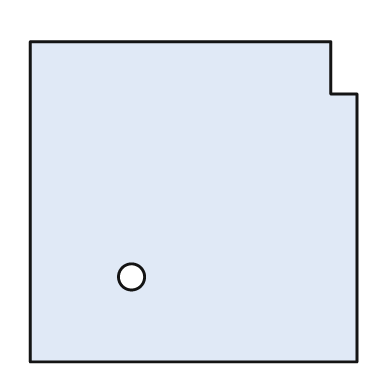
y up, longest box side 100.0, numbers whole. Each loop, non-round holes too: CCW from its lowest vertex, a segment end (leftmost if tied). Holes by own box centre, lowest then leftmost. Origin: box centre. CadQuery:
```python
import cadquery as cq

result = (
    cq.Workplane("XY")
    .moveTo(-50.0, -49.0)
    .lineTo(50.0, -49.0)
    .lineTo(50.0, 33.0)
    .lineTo(42.0, 33.0)
    .lineTo(42.0, 49.0)
    .lineTo(-50.0, 49.0)
    .close()
    .moveTo(-19.0, -23.0)
    .circle(4.0)
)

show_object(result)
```